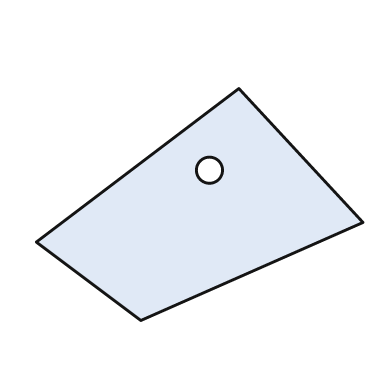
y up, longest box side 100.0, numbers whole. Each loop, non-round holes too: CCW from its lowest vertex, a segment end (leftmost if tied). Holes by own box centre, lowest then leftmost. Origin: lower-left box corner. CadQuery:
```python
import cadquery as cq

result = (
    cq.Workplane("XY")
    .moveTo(32.0, 0.0)
    .lineTo(100.0, 30.0)
    .lineTo(62.0, 71.0)
    .lineTo(0.0, 24.0)
    .close()
    .moveTo(53.0, 46.0)
    .circle(4.0)
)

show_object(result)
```